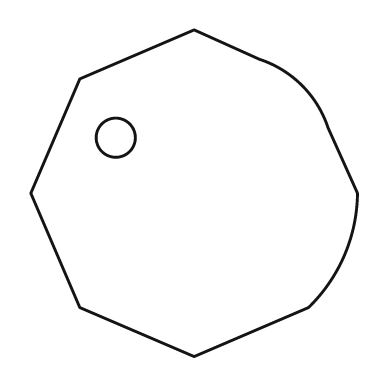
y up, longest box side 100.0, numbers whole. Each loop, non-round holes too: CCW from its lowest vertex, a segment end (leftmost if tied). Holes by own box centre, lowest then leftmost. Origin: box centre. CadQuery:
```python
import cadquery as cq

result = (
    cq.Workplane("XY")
    .moveTo(0.0, -50.0)
    .lineTo(35.0, -35.0)
    .threePointArc((46.0, -19.0), (50.0, 0.0))
    .lineTo(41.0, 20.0)
    .threePointArc((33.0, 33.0), (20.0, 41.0))
    .lineTo(0.0, 50.0)
    .lineTo(-35.0, 35.0)
    .lineTo(-50.0, 0.0)
    .lineTo(-35.0, -35.0)
    .close()
    .moveTo(-24.0, 17.0)
    .circle(6.0)
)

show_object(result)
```